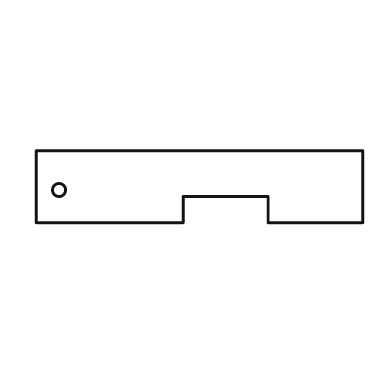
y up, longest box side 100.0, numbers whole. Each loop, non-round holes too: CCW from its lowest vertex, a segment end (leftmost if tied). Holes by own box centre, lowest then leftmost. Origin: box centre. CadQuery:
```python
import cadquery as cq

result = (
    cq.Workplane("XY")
    .moveTo(-50.0, -11.0)
    .lineTo(-5.0, -11.0)
    .lineTo(-5.0, -3.0)
    .lineTo(21.0, -3.0)
    .lineTo(21.0, -11.0)
    .lineTo(50.0, -11.0)
    .lineTo(50.0, 11.0)
    .lineTo(-50.0, 11.0)
    .close()
    .moveTo(-43.0, -1.0)
    .circle(2.0)
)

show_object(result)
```